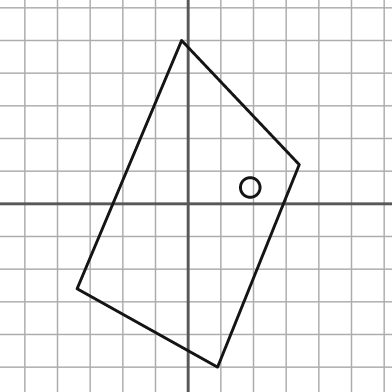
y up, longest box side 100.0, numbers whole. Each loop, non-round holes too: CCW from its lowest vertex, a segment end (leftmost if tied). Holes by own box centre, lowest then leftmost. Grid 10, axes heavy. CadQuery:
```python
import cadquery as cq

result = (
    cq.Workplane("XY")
    .moveTo(9.0, -50.0)
    .lineTo(34.0, 12.0)
    .lineTo(-2.0, 50.0)
    .lineTo(-34.0, -26.0)
    .close()
    .moveTo(19.0, 5.0)
    .circle(3.0)
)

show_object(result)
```